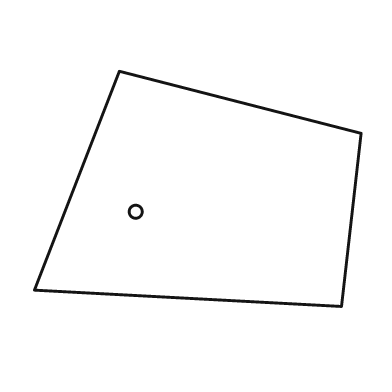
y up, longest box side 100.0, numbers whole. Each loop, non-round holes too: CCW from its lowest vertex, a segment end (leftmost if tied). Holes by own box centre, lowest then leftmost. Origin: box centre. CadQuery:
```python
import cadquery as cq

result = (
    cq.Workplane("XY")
    .moveTo(44.0, -36.0)
    .lineTo(50.0, 17.0)
    .lineTo(-24.0, 36.0)
    .lineTo(-50.0, -31.0)
    .close()
    .moveTo(-19.0, -7.0)
    .circle(2.0)
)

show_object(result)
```